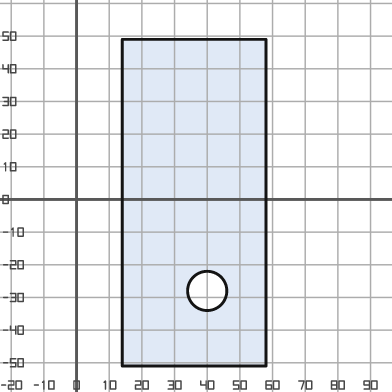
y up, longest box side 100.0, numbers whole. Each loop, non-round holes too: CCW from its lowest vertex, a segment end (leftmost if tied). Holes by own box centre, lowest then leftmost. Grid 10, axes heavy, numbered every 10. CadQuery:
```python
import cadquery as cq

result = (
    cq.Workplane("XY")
    .moveTo(14.0, -51.0)
    .lineTo(58.0, -51.0)
    .lineTo(58.0, 49.0)
    .lineTo(14.0, 49.0)
    .close()
    .moveTo(40.0, -28.0)
    .circle(6.0)
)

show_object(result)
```